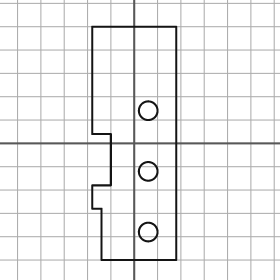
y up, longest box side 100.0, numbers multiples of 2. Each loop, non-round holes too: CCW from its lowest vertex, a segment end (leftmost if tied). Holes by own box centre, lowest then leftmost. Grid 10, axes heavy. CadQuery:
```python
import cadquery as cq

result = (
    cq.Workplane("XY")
    .moveTo(-14.0, -50.0)
    .lineTo(18.0, -50.0)
    .lineTo(18.0, 50.0)
    .lineTo(-18.0, 50.0)
    .lineTo(-18.0, 4.0)
    .lineTo(-10.0, 4.0)
    .lineTo(-10.0, -18.0)
    .lineTo(-18.0, -18.0)
    .lineTo(-18.0, -28.0)
    .lineTo(-14.0, -28.0)
    .close()
    .moveTo(6.0, -38.0)
    .circle(4.0)
    .moveTo(6.0, -12.0)
    .circle(4.0)
    .moveTo(6.0, 14.0)
    .circle(4.0)
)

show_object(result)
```